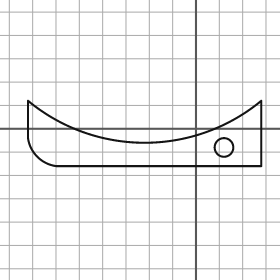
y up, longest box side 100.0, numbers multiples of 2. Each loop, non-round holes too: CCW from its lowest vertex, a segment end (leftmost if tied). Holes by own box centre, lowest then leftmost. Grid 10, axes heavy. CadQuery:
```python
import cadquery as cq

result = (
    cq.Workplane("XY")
    .moveTo(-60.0, -16.0)
    .lineTo(28.0, -16.0)
    .lineTo(28.0, 12.0)
    .threePointArc((-22.0, -6.0), (-72.0, 12.0))
    .lineTo(-72.0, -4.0)
    .threePointArc((-68.0, -12.0), (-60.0, -16.0))
    .close()
    .moveTo(12.0, -8.0)
    .circle(4.0)
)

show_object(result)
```